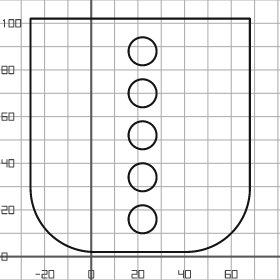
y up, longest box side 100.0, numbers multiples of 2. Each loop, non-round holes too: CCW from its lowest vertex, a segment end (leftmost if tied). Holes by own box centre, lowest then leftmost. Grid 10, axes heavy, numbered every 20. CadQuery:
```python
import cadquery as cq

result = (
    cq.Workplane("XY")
    .moveTo(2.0, 2.0)
    .lineTo(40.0, 2.0)
    .threePointArc((60.0, 10.0), (68.0, 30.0))
    .lineTo(68.0, 102.0)
    .lineTo(-26.0, 102.0)
    .lineTo(-26.0, 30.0)
    .threePointArc((-18.0, 10.0), (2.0, 2.0))
    .close()
    .moveTo(22.0, 16.0)
    .circle(6.0)
    .moveTo(22.0, 34.0)
    .circle(6.0)
    .moveTo(22.0, 52.0)
    .circle(6.0)
    .moveTo(22.0, 70.0)
    .circle(6.0)
    .moveTo(22.0, 88.0)
    .circle(6.0)
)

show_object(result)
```